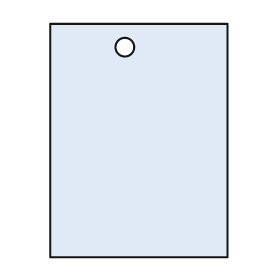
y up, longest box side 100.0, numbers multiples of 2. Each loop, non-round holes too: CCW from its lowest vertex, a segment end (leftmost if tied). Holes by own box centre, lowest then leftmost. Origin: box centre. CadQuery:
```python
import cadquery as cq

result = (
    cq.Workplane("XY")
    .moveTo(-38.0, -50.0)
    .lineTo(38.0, -50.0)
    .lineTo(38.0, 50.0)
    .lineTo(-38.0, 50.0)
    .close()
    .moveTo(-6.0, 40.0)
    .circle(4.0)
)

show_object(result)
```